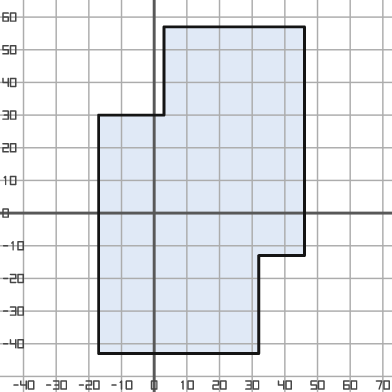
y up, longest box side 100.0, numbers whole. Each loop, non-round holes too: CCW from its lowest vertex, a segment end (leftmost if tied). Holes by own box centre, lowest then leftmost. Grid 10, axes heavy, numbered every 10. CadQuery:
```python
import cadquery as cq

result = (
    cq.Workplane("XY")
    .moveTo(-17.0, -43.0)
    .lineTo(32.0, -43.0)
    .lineTo(32.0, -13.0)
    .lineTo(46.0, -13.0)
    .lineTo(46.0, 57.0)
    .lineTo(3.0, 57.0)
    .lineTo(3.0, 30.0)
    .lineTo(-17.0, 30.0)
    .close()
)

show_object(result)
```